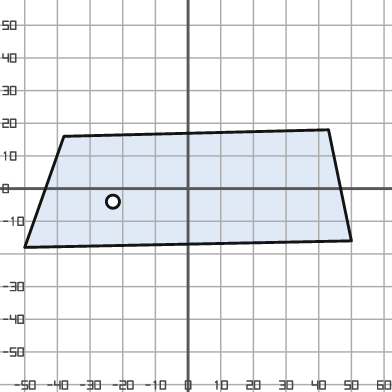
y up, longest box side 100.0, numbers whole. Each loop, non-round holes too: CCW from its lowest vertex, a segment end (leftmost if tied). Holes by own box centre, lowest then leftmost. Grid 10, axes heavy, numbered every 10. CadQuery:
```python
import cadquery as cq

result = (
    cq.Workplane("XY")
    .moveTo(-50.0, -18.0)
    .lineTo(50.0, -16.0)
    .lineTo(43.0, 18.0)
    .lineTo(-38.0, 16.0)
    .close()
    .moveTo(-23.0, -4.0)
    .circle(2.0)
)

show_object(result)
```